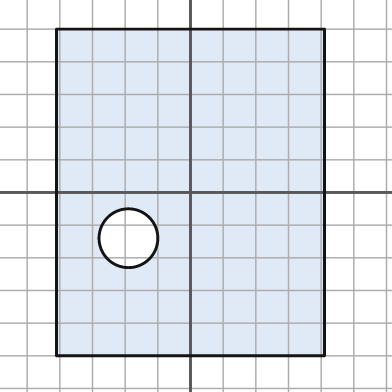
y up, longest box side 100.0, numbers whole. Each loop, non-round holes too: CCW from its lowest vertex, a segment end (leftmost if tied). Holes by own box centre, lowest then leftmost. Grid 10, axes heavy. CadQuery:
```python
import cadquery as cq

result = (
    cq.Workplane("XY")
    .moveTo(-41.0, -50.0)
    .lineTo(41.0, -50.0)
    .lineTo(41.0, 50.0)
    .lineTo(-41.0, 50.0)
    .close()
    .moveTo(-19.0, -14.0)
    .circle(9.0)
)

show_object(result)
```